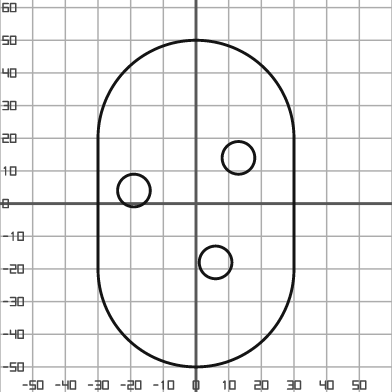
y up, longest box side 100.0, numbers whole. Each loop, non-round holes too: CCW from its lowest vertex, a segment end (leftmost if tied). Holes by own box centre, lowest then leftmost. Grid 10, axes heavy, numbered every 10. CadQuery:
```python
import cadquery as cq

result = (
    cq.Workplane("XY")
    .moveTo(-30.0, -20.0)
    .threePointArc((0.0, -50.0), (30.0, -20.0))
    .lineTo(30.0, 20.0)
    .threePointArc((0.0, 50.0), (-30.0, 20.0))
    .close()
    .moveTo(6.0, -18.0)
    .circle(5.0)
    .moveTo(-19.0, 4.0)
    .circle(5.0)
    .moveTo(13.0, 14.0)
    .circle(5.0)
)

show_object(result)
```